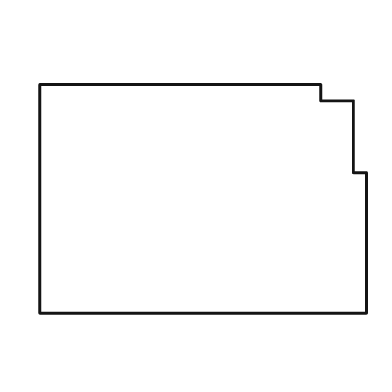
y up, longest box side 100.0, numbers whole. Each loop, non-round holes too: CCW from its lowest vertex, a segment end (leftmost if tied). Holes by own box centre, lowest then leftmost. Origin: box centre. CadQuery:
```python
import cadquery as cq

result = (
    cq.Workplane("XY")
    .moveTo(-50.0, -35.0)
    .lineTo(50.0, -35.0)
    .lineTo(50.0, 8.0)
    .lineTo(46.0, 8.0)
    .lineTo(46.0, 30.0)
    .lineTo(36.0, 30.0)
    .lineTo(36.0, 35.0)
    .lineTo(-50.0, 35.0)
    .close()
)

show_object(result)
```